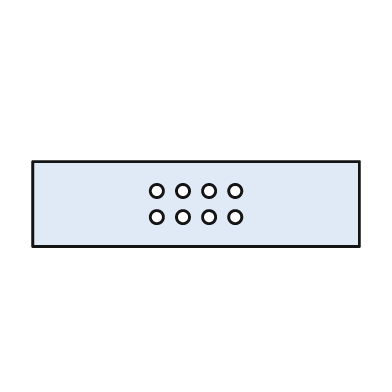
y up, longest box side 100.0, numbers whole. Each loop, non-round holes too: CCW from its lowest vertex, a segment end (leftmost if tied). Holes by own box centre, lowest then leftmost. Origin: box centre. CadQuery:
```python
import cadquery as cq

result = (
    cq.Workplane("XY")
    .moveTo(-50.0, -13.0)
    .lineTo(50.0, -13.0)
    .lineTo(50.0, 13.0)
    .lineTo(-50.0, 13.0)
    .close()
    .moveTo(-12.0, -4.0)
    .circle(2.0)
    .moveTo(-4.0, -4.0)
    .circle(2.0)
    .moveTo(4.0, -4.0)
    .circle(2.0)
    .moveTo(12.0, -4.0)
    .circle(2.0)
    .moveTo(-12.0, 4.0)
    .circle(2.0)
    .moveTo(-4.0, 4.0)
    .circle(2.0)
    .moveTo(4.0, 4.0)
    .circle(2.0)
    .moveTo(12.0, 4.0)
    .circle(2.0)
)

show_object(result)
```